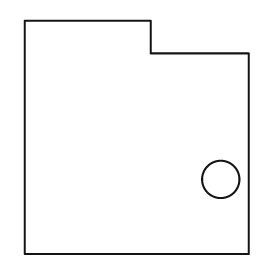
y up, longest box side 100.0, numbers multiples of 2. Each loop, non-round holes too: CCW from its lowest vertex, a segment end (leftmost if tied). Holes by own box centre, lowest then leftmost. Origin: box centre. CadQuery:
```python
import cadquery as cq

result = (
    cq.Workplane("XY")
    .moveTo(-48.0, -50.0)
    .lineTo(48.0, -50.0)
    .lineTo(48.0, 36.0)
    .lineTo(6.0, 36.0)
    .lineTo(6.0, 50.0)
    .lineTo(-48.0, 50.0)
    .close()
    .moveTo(36.0, -18.0)
    .circle(8.0)
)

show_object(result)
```